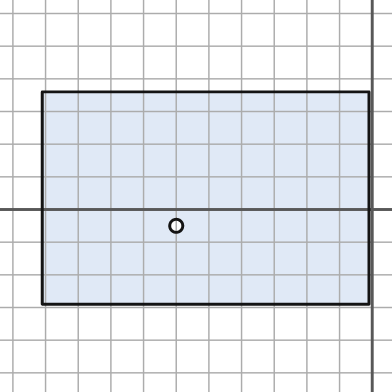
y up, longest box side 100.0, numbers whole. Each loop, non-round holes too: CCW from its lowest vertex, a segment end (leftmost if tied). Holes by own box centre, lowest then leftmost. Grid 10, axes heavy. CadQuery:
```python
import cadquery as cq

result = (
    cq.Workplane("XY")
    .moveTo(-101.0, -29.0)
    .lineTo(-1.0, -29.0)
    .lineTo(-1.0, 36.0)
    .lineTo(-101.0, 36.0)
    .close()
    .moveTo(-60.0, -5.0)
    .circle(2.0)
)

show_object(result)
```